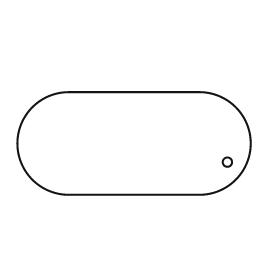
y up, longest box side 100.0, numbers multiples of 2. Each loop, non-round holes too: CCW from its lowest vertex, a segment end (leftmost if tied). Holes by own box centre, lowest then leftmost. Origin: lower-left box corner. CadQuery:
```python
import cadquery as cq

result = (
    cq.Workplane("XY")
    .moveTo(22.0, 0.0)
    .lineTo(78.0, 0.0)
    .threePointArc((100.0, 22.0), (78.0, 44.0))
    .lineTo(22.0, 44.0)
    .threePointArc((0.0, 22.0), (22.0, 0.0))
    .close()
    .moveTo(90.0, 14.0)
    .circle(2.0)
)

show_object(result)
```